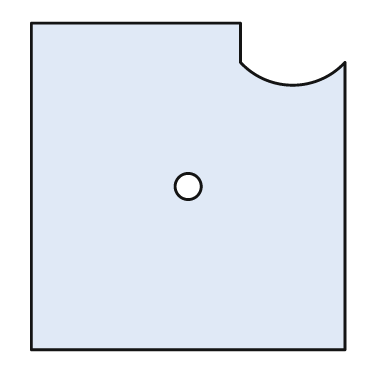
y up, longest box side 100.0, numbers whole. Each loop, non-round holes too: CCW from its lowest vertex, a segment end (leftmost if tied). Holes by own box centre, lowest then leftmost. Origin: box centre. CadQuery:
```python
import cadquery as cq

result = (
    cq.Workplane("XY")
    .moveTo(-48.0, -50.0)
    .lineTo(48.0, -50.0)
    .lineTo(48.0, 38.0)
    .threePointArc((32.0, 31.0), (16.0, 38.0))
    .lineTo(16.0, 50.0)
    .lineTo(-48.0, 50.0)
    .close()
    .moveTo(0.0, 0.0)
    .circle(4.0)
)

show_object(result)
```